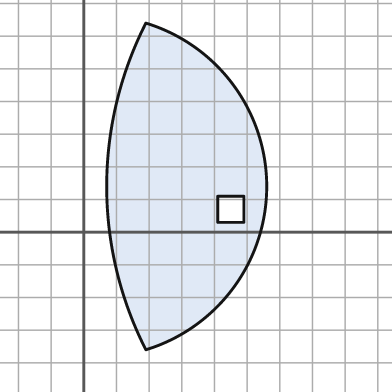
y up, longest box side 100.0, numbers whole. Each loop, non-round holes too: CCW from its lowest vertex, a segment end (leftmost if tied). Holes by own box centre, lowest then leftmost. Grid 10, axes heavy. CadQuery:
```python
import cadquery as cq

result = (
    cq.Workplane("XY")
    .moveTo(19.0, -36.0)
    .threePointArc((56.0, 14.0), (19.0, 64.0))
    .threePointArc((7.0, 14.0), (19.0, -36.0))
    .close()
    .moveTo(41.0, 3.0)
    .lineTo(49.0, 3.0)
    .lineTo(49.0, 11.0)
    .lineTo(41.0, 11.0)
    .close()
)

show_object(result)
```